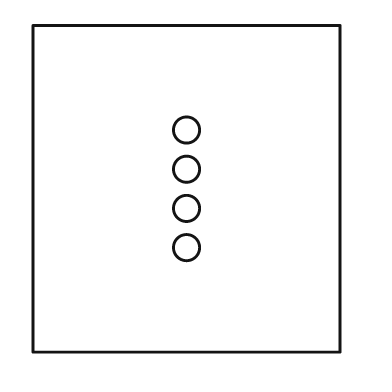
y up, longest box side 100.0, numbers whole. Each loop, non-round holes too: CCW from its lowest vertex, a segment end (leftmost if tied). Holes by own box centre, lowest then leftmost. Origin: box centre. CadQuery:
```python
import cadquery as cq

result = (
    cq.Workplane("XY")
    .moveTo(-47.0, -50.0)
    .lineTo(47.0, -50.0)
    .lineTo(47.0, 50.0)
    .lineTo(-47.0, 50.0)
    .close()
    .moveTo(0.0, -18.0)
    .circle(4.0)
    .moveTo(0.0, -6.0)
    .circle(4.0)
    .moveTo(0.0, 6.0)
    .circle(4.0)
    .moveTo(0.0, 18.0)
    .circle(4.0)
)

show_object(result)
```